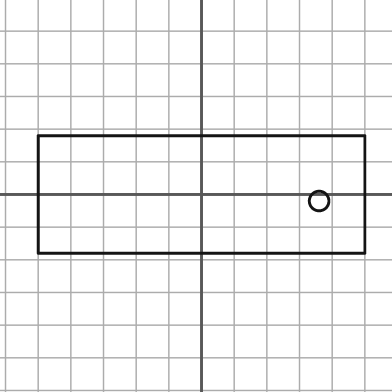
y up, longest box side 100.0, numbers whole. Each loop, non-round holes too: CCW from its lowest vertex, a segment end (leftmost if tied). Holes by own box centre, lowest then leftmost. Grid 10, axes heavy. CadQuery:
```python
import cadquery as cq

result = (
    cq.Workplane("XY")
    .moveTo(-50.0, -18.0)
    .lineTo(50.0, -18.0)
    .lineTo(50.0, 18.0)
    .lineTo(-50.0, 18.0)
    .close()
    .moveTo(36.0, -2.0)
    .circle(3.0)
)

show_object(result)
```